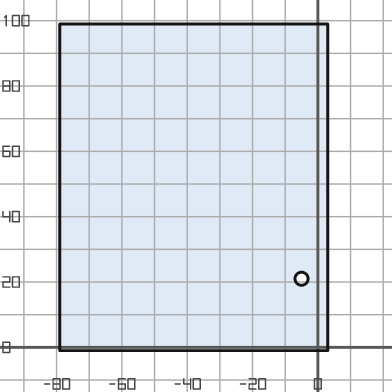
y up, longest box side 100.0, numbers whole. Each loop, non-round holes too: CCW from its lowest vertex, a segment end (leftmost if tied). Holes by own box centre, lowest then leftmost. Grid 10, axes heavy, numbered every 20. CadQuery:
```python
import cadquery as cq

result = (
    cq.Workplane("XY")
    .moveTo(-79.0, -1.0)
    .lineTo(3.0, -1.0)
    .lineTo(3.0, 99.0)
    .lineTo(-79.0, 99.0)
    .close()
    .moveTo(-5.0, 21.0)
    .circle(2.0)
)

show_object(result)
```